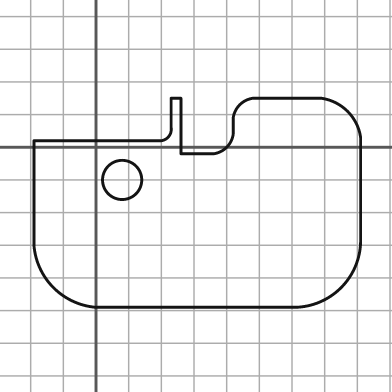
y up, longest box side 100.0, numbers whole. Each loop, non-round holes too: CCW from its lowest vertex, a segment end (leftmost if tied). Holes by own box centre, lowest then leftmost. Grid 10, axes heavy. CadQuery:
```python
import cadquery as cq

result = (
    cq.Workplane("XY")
    .moveTo(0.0, -49.0)
    .lineTo(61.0, -49.0)
    .threePointArc((75.0, -43.0), (81.0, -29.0))
    .lineTo(81.0, 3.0)
    .threePointArc((77.0, 11.0), (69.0, 15.0))
    .lineTo(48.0, 15.0)
    .threePointArc((44.0, 13.0), (42.0, 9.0))
    .lineTo(42.0, 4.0)
    .threePointArc((40.0, 0.0), (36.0, -2.0))
    .lineTo(26.0, -2.0)
    .lineTo(26.0, 15.0)
    .lineTo(23.0, 15.0)
    .lineTo(23.0, 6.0)
    .threePointArc((22.0, 3.0), (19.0, 2.0))
    .lineTo(-19.0, 2.0)
    .lineTo(-19.0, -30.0)
    .threePointArc((-13.0, -43.0), (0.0, -49.0))
    .close()
    .moveTo(8.0, -10.0)
    .circle(6.0)
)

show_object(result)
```